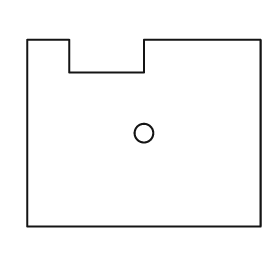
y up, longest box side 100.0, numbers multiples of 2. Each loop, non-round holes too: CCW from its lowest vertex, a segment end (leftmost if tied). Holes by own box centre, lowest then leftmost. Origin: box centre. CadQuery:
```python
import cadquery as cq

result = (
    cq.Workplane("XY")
    .moveTo(-50.0, -40.0)
    .lineTo(50.0, -40.0)
    .lineTo(50.0, 40.0)
    .lineTo(0.0, 40.0)
    .lineTo(0.0, 26.0)
    .lineTo(-32.0, 26.0)
    .lineTo(-32.0, 40.0)
    .lineTo(-50.0, 40.0)
    .close()
    .moveTo(0.0, 0.0)
    .circle(4.0)
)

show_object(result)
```